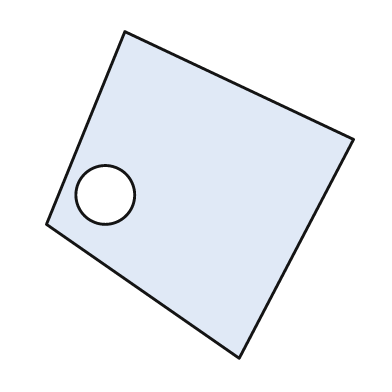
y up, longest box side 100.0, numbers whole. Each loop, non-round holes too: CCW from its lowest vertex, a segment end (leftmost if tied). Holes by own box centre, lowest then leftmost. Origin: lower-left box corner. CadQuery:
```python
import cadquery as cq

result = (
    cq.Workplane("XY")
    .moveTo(59.0, 0.0)
    .lineTo(94.0, 67.0)
    .lineTo(24.0, 100.0)
    .lineTo(0.0, 41.0)
    .close()
    .moveTo(18.0, 50.0)
    .circle(9.0)
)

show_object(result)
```